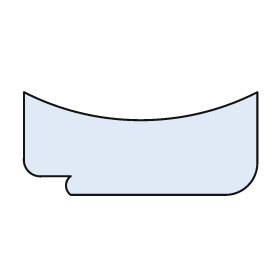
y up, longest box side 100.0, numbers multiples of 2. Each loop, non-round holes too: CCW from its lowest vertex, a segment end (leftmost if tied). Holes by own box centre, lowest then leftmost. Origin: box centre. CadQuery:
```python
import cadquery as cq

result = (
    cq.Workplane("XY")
    .moveTo(-30.0, -22.0)
    .lineTo(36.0, -22.0)
    .threePointArc((46.0, -18.0), (50.0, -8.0))
    .lineTo(50.0, 22.0)
    .threePointArc((0.0, 10.0), (-50.0, 22.0))
    .lineTo(-50.0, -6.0)
    .threePointArc((-48.0, -12.0), (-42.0, -14.0))
    .lineTo(-30.0, -14.0)
    .threePointArc((-32.0, -18.0), (-30.0, -22.0))
    .close()
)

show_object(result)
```